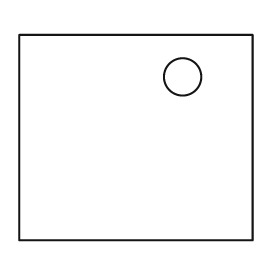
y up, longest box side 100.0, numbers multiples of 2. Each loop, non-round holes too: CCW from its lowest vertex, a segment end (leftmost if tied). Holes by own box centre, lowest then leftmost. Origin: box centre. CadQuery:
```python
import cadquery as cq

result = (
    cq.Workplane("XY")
    .moveTo(-50.0, -44.0)
    .lineTo(50.0, -44.0)
    .lineTo(50.0, 44.0)
    .lineTo(-50.0, 44.0)
    .close()
    .moveTo(20.0, 26.0)
    .circle(8.0)
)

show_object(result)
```